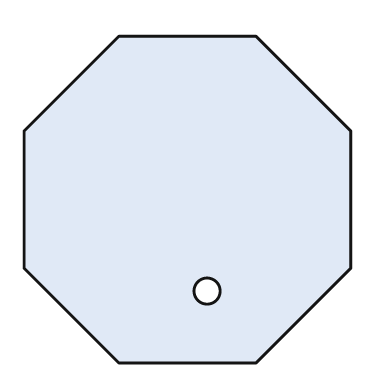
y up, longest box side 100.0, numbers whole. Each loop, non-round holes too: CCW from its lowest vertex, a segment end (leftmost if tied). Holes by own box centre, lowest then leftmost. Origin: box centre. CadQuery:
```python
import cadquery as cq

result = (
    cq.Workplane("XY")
    .moveTo(-21.0, -50.0)
    .lineTo(21.0, -50.0)
    .lineTo(50.0, -21.0)
    .lineTo(50.0, 21.0)
    .lineTo(21.0, 50.0)
    .lineTo(-21.0, 50.0)
    .lineTo(-50.0, 21.0)
    .lineTo(-50.0, -21.0)
    .close()
    .moveTo(6.0, -28.0)
    .circle(4.0)
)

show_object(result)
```